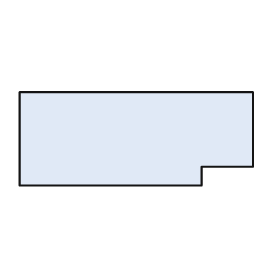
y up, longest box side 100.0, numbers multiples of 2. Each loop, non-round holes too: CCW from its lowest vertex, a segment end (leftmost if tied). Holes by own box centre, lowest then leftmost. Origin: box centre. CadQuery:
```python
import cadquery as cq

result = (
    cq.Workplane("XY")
    .moveTo(-50.0, -20.0)
    .lineTo(28.0, -20.0)
    .lineTo(28.0, -12.0)
    .lineTo(50.0, -12.0)
    .lineTo(50.0, 20.0)
    .lineTo(-50.0, 20.0)
    .close()
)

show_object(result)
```